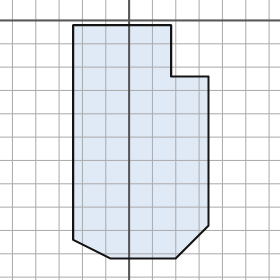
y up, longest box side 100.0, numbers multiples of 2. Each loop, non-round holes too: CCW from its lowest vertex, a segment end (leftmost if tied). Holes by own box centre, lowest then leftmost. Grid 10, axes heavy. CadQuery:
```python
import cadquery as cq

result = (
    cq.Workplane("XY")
    .moveTo(-8.0, -102.0)
    .lineTo(20.0, -102.0)
    .lineTo(34.0, -88.0)
    .lineTo(34.0, -24.0)
    .lineTo(18.0, -24.0)
    .lineTo(18.0, -2.0)
    .lineTo(-24.0, -2.0)
    .lineTo(-24.0, -94.0)
    .close()
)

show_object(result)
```